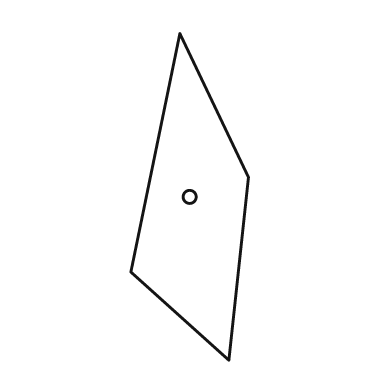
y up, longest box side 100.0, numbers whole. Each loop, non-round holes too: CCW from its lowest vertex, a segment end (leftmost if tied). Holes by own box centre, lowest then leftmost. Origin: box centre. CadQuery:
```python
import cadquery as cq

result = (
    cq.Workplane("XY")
    .moveTo(12.0, -50.0)
    .lineTo(18.0, 6.0)
    .lineTo(-3.0, 50.0)
    .lineTo(-18.0, -23.0)
    .close()
    .moveTo(0.0, 0.0)
    .circle(2.0)
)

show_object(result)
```